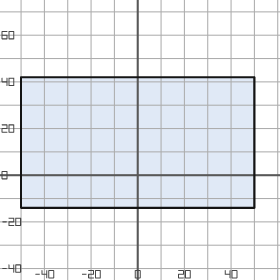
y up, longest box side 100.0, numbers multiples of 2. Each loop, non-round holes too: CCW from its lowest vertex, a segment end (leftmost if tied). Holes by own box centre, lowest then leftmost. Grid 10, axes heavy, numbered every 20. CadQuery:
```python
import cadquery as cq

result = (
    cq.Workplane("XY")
    .moveTo(-50.0, -14.0)
    .lineTo(50.0, -14.0)
    .lineTo(50.0, 42.0)
    .lineTo(-50.0, 42.0)
    .close()
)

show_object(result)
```